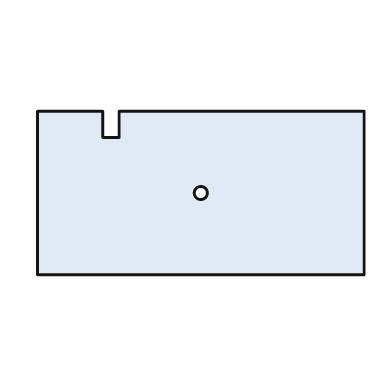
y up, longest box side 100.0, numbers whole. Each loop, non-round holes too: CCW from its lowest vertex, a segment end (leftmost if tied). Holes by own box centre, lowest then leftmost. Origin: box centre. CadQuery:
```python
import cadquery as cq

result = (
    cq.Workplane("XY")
    .moveTo(-50.0, -25.0)
    .lineTo(50.0, -25.0)
    .lineTo(50.0, 25.0)
    .lineTo(-25.0, 25.0)
    .lineTo(-25.0, 17.0)
    .lineTo(-30.0, 17.0)
    .lineTo(-30.0, 25.0)
    .lineTo(-50.0, 25.0)
    .close()
    .moveTo(0.0, 0.0)
    .circle(2.0)
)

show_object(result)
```